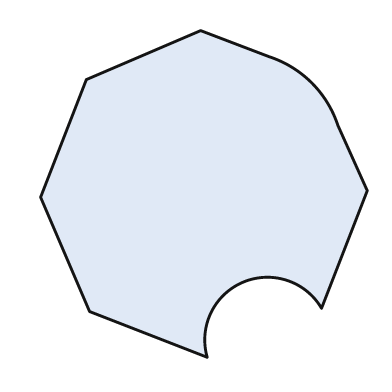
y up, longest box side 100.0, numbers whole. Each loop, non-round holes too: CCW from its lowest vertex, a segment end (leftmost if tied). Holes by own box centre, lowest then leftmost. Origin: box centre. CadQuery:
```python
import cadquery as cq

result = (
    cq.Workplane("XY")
    .moveTo(1.0, -50.0)
    .threePointArc((12.0, -27.0), (36.0, -35.0))
    .lineTo(50.0, 1.0)
    .lineTo(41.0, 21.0)
    .threePointArc((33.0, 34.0), (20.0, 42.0))
    .lineTo(-1.0, 50.0)
    .lineTo(-36.0, 35.0)
    .lineTo(-50.0, -1.0)
    .lineTo(-35.0, -36.0)
    .close()
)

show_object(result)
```